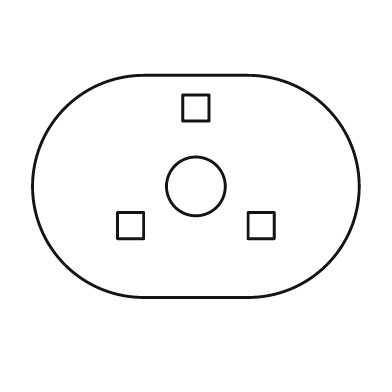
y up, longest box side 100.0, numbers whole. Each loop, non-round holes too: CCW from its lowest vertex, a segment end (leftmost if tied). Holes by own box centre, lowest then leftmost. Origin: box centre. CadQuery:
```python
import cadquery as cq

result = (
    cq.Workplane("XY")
    .moveTo(-16.0, -34.0)
    .lineTo(16.0, -34.0)
    .threePointArc((50.0, 0.0), (16.0, 34.0))
    .lineTo(-16.0, 34.0)
    .threePointArc((-50.0, 0.0), (-16.0, -34.0))
    .close()
    .moveTo(-24.0, -16.0)
    .lineTo(-16.0, -16.0)
    .lineTo(-16.0, -8.0)
    .lineTo(-24.0, -8.0)
    .close()
    .moveTo(16.0, -16.0)
    .lineTo(24.0, -16.0)
    .lineTo(24.0, -8.0)
    .lineTo(16.0, -8.0)
    .close()
    .moveTo(0.0, 0.0)
    .circle(9.0)
    .moveTo(-4.0, 20.0)
    .lineTo(4.0, 20.0)
    .lineTo(4.0, 28.0)
    .lineTo(-4.0, 28.0)
    .close()
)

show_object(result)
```